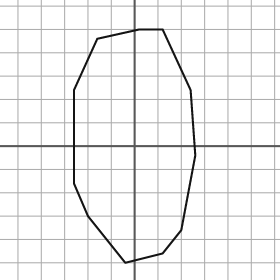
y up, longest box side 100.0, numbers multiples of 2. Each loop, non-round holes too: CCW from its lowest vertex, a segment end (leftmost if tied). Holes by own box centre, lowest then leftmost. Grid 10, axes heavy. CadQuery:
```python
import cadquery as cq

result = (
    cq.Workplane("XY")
    .moveTo(-4.0, -50.0)
    .lineTo(12.0, -46.0)
    .lineTo(20.0, -36.0)
    .lineTo(26.0, -4.0)
    .lineTo(24.0, 24.0)
    .lineTo(12.0, 50.0)
    .lineTo(2.0, 50.0)
    .lineTo(-16.0, 46.0)
    .lineTo(-26.0, 24.0)
    .lineTo(-26.0, -16.0)
    .lineTo(-20.0, -30.0)
    .close()
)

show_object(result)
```